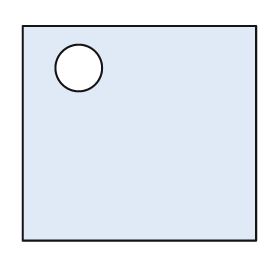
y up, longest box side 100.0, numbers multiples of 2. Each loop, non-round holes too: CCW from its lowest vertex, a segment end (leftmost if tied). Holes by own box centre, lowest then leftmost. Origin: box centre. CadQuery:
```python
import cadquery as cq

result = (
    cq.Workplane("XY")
    .moveTo(-50.0, -46.0)
    .lineTo(50.0, -46.0)
    .lineTo(50.0, 46.0)
    .lineTo(-50.0, 46.0)
    .close()
    .moveTo(-26.0, 28.0)
    .circle(10.0)
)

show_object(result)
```